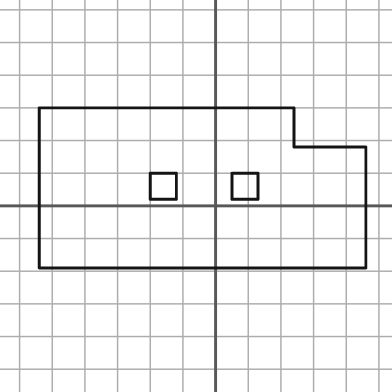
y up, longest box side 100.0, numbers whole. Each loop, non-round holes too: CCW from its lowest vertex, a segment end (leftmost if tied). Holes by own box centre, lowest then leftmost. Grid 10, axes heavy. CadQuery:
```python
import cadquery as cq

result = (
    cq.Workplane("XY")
    .moveTo(-54.0, -19.0)
    .lineTo(46.0, -19.0)
    .lineTo(46.0, 18.0)
    .lineTo(24.0, 18.0)
    .lineTo(24.0, 30.0)
    .lineTo(-54.0, 30.0)
    .close()
    .moveTo(-20.0, 2.0)
    .lineTo(-12.0, 2.0)
    .lineTo(-12.0, 10.0)
    .lineTo(-20.0, 10.0)
    .close()
    .moveTo(5.0, 2.0)
    .lineTo(13.0, 2.0)
    .lineTo(13.0, 10.0)
    .lineTo(5.0, 10.0)
    .close()
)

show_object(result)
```